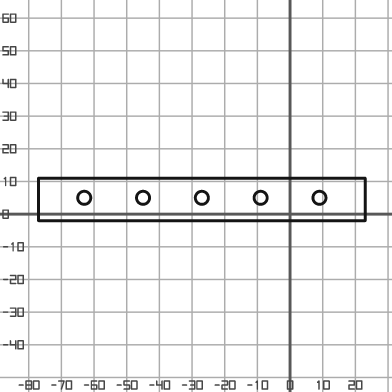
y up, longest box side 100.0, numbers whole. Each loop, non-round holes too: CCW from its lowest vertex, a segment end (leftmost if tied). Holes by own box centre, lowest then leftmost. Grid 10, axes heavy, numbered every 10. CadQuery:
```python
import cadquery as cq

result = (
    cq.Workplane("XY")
    .moveTo(-77.0, -2.0)
    .lineTo(23.0, -2.0)
    .lineTo(23.0, 11.0)
    .lineTo(-77.0, 11.0)
    .close()
    .moveTo(-63.0, 5.0)
    .circle(2.0)
    .moveTo(-45.0, 5.0)
    .circle(2.0)
    .moveTo(-27.0, 5.0)
    .circle(2.0)
    .moveTo(-9.0, 5.0)
    .circle(2.0)
    .moveTo(9.0, 5.0)
    .circle(2.0)
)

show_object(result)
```